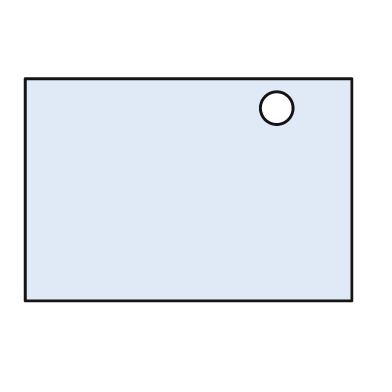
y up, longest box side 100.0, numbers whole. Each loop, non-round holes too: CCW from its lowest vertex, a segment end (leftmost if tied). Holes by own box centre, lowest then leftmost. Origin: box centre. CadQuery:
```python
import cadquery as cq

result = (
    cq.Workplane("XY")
    .moveTo(-50.0, -34.0)
    .lineTo(50.0, -34.0)
    .lineTo(50.0, 34.0)
    .lineTo(-50.0, 34.0)
    .close()
    .moveTo(27.0, 25.0)
    .circle(5.0)
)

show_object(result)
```